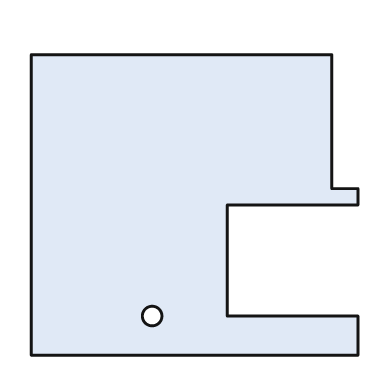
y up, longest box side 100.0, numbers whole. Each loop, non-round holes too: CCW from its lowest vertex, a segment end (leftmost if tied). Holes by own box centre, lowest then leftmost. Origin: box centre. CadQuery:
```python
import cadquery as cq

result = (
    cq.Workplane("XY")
    .moveTo(-50.0, -46.0)
    .lineTo(50.0, -46.0)
    .lineTo(50.0, -34.0)
    .lineTo(10.0, -34.0)
    .lineTo(10.0, 0.0)
    .lineTo(50.0, 0.0)
    .lineTo(50.0, 5.0)
    .lineTo(42.0, 5.0)
    .lineTo(42.0, 46.0)
    .lineTo(-50.0, 46.0)
    .close()
    .moveTo(-13.0, -34.0)
    .circle(3.0)
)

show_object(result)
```